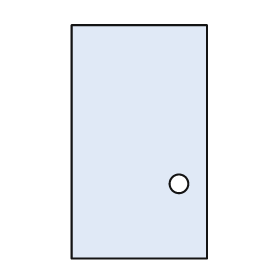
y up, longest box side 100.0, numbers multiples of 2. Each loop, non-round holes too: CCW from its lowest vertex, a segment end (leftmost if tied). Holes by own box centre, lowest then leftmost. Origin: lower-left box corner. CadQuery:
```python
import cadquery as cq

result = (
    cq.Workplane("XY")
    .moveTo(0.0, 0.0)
    .lineTo(58.0, 0.0)
    .lineTo(58.0, 100.0)
    .lineTo(0.0, 100.0)
    .close()
    .moveTo(46.0, 32.0)
    .circle(4.0)
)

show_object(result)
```